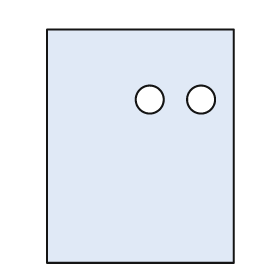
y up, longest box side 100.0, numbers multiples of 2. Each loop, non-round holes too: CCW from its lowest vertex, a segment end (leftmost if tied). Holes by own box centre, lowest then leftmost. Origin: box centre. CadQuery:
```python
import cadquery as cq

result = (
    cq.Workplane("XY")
    .moveTo(-40.0, -50.0)
    .lineTo(40.0, -50.0)
    .lineTo(40.0, 50.0)
    .lineTo(-40.0, 50.0)
    .close()
    .moveTo(4.0, 20.0)
    .circle(6.0)
    .moveTo(26.0, 20.0)
    .circle(6.0)
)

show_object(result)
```